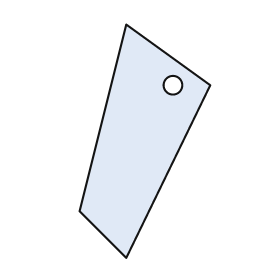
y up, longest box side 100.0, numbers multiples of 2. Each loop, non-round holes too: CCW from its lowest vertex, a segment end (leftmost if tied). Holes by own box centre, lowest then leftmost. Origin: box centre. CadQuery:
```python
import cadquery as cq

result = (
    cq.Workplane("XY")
    .moveTo(-8.0, -50.0)
    .lineTo(28.0, 24.0)
    .lineTo(-8.0, 50.0)
    .lineTo(-28.0, -30.0)
    .close()
    .moveTo(12.0, 24.0)
    .circle(4.0)
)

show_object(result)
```